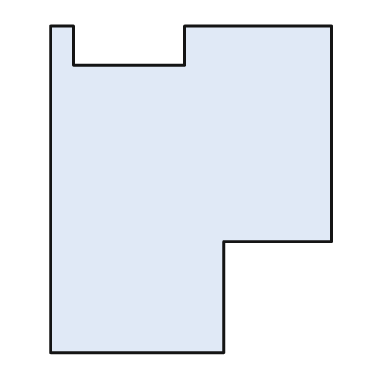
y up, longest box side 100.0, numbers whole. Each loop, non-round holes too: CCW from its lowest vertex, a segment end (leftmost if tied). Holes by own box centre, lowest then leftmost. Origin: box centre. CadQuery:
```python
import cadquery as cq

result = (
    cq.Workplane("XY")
    .moveTo(-43.0, -50.0)
    .lineTo(10.0, -50.0)
    .lineTo(10.0, -16.0)
    .lineTo(43.0, -16.0)
    .lineTo(43.0, 50.0)
    .lineTo(-2.0, 50.0)
    .lineTo(-2.0, 38.0)
    .lineTo(-36.0, 38.0)
    .lineTo(-36.0, 50.0)
    .lineTo(-43.0, 50.0)
    .close()
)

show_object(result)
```